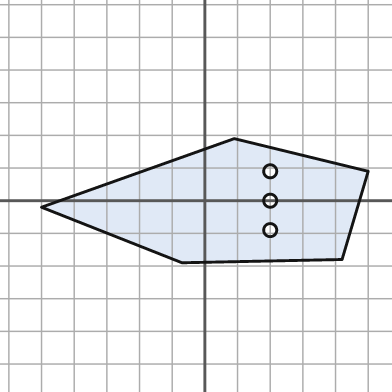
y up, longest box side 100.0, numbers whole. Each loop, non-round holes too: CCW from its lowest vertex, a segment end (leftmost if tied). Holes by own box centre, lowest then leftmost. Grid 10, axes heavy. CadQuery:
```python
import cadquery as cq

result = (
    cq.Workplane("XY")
    .moveTo(-7.0, -19.0)
    .lineTo(42.0, -18.0)
    .lineTo(50.0, 9.0)
    .lineTo(9.0, 19.0)
    .lineTo(-50.0, -2.0)
    .close()
    .moveTo(20.0, -9.0)
    .circle(2.0)
    .moveTo(20.0, 0.0)
    .circle(2.0)
    .moveTo(20.0, 9.0)
    .circle(2.0)
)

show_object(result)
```